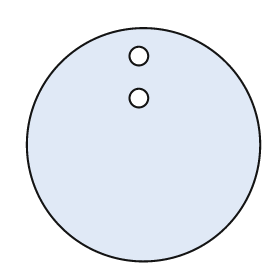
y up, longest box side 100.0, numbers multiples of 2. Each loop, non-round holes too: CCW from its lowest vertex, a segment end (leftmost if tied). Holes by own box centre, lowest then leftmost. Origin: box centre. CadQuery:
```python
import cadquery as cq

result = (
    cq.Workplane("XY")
    .moveTo(0.0, 0.0)
    .circle(50.0)
    .moveTo(-2.0, 20.0)
    .circle(4.0)
    .moveTo(-2.0, 38.0)
    .circle(4.0)
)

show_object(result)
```